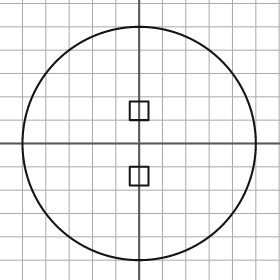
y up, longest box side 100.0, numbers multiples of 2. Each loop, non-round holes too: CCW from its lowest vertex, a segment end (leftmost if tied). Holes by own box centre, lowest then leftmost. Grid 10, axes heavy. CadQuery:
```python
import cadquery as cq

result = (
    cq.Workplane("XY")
    .moveTo(0.0, 0.0)
    .circle(50.0)
    .moveTo(-4.0, -18.0)
    .lineTo(4.0, -18.0)
    .lineTo(4.0, -10.0)
    .lineTo(-4.0, -10.0)
    .close()
    .moveTo(-4.0, 10.0)
    .lineTo(4.0, 10.0)
    .lineTo(4.0, 18.0)
    .lineTo(-4.0, 18.0)
    .close()
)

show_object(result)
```